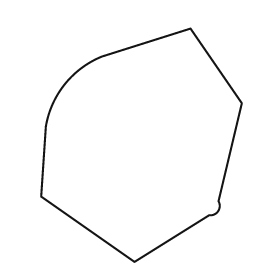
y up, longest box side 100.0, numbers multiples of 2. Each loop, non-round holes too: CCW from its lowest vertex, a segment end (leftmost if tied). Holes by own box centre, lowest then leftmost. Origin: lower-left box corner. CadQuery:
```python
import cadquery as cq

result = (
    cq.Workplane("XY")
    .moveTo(40.0, 0.0)
    .lineTo(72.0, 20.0)
    .threePointArc((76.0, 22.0), (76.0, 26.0))
    .lineTo(86.0, 68.0)
    .lineTo(64.0, 100.0)
    .lineTo(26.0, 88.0)
    .threePointArc((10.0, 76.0), (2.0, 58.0))
    .lineTo(0.0, 28.0)
    .close()
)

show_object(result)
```